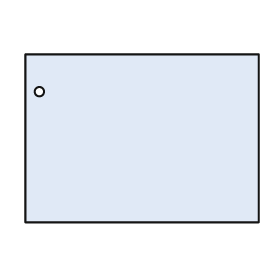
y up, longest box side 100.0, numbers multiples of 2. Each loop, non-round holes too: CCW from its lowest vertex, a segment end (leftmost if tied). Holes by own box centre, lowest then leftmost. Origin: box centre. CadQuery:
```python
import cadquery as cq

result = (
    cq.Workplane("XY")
    .moveTo(-50.0, -36.0)
    .lineTo(50.0, -36.0)
    .lineTo(50.0, 36.0)
    .lineTo(-50.0, 36.0)
    .close()
    .moveTo(-44.0, 20.0)
    .circle(2.0)
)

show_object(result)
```